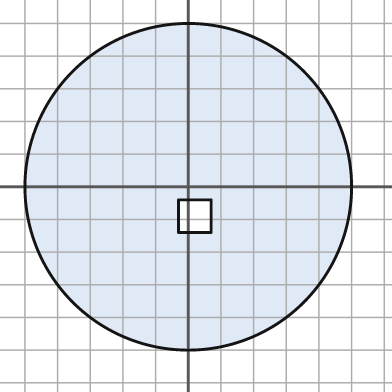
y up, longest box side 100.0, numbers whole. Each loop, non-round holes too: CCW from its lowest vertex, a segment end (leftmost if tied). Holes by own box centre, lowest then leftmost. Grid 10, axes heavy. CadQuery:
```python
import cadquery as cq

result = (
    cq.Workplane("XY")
    .moveTo(0.0, 0.0)
    .circle(50.0)
    .moveTo(-3.0, -14.0)
    .lineTo(7.0, -14.0)
    .lineTo(7.0, -4.0)
    .lineTo(-3.0, -4.0)
    .close()
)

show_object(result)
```